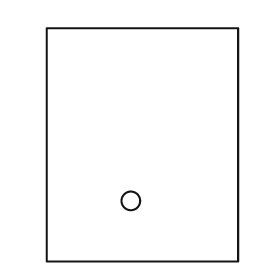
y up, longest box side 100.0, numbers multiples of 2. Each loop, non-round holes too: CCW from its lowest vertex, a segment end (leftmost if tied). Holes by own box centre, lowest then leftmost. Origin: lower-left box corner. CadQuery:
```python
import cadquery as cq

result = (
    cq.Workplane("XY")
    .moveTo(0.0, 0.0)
    .lineTo(82.0, 0.0)
    .lineTo(82.0, 100.0)
    .lineTo(0.0, 100.0)
    .close()
    .moveTo(36.0, 26.0)
    .circle(4.0)
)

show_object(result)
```